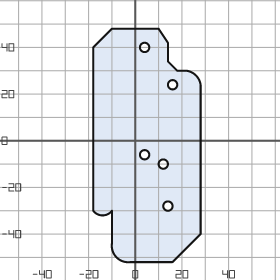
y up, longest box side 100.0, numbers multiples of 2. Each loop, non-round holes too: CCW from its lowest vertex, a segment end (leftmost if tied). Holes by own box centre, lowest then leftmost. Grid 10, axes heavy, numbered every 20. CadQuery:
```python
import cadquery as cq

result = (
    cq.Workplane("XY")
    .moveTo(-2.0, -52.0)
    .lineTo(16.0, -52.0)
    .lineTo(28.0, -40.0)
    .lineTo(28.0, 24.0)
    .threePointArc((26.0, 28.0), (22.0, 30.0))
    .lineTo(18.0, 30.0)
    .lineTo(14.0, 34.0)
    .lineTo(14.0, 42.0)
    .lineTo(10.0, 48.0)
    .lineTo(-10.0, 48.0)
    .lineTo(-18.0, 40.0)
    .lineTo(-18.0, -30.0)
    .threePointArc((-14.0, -32.0), (-10.0, -30.0))
    .lineTo(-10.0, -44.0)
    .threePointArc((-8.0, -50.0), (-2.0, -52.0))
    .close()
    .moveTo(14.0, -28.0)
    .circle(2.0)
    .moveTo(12.0, -10.0)
    .circle(2.0)
    .moveTo(4.0, -6.0)
    .circle(2.0)
    .moveTo(16.0, 24.0)
    .circle(2.0)
    .moveTo(4.0, 40.0)
    .circle(2.0)
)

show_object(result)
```